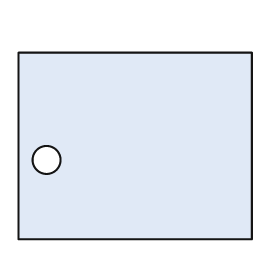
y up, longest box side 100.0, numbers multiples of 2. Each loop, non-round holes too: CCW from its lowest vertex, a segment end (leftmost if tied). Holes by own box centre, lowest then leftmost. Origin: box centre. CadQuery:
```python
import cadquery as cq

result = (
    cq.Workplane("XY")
    .moveTo(-50.0, -40.0)
    .lineTo(50.0, -40.0)
    .lineTo(50.0, 40.0)
    .lineTo(-50.0, 40.0)
    .close()
    .moveTo(-38.0, -6.0)
    .circle(6.0)
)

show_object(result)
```